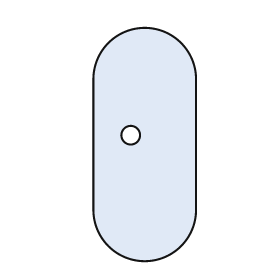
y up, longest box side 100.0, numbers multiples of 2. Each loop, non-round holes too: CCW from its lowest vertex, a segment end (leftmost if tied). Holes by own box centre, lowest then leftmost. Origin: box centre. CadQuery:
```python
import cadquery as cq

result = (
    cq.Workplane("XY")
    .moveTo(-22.0, -28.0)
    .threePointArc((0.0, -50.0), (22.0, -28.0))
    .lineTo(22.0, 28.0)
    .threePointArc((0.0, 50.0), (-22.0, 28.0))
    .close()
    .moveTo(-6.0, 4.0)
    .circle(4.0)
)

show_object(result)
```